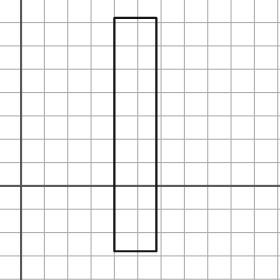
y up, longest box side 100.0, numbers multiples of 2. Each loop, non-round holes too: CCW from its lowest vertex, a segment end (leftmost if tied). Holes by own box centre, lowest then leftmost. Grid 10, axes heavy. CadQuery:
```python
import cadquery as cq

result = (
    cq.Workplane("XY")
    .moveTo(40.0, -28.0)
    .lineTo(58.0, -28.0)
    .lineTo(58.0, 72.0)
    .lineTo(40.0, 72.0)
    .close()
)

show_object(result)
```